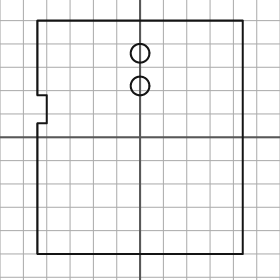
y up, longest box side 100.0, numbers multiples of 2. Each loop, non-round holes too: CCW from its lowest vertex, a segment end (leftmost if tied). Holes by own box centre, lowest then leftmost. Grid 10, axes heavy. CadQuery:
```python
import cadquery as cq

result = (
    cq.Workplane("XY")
    .moveTo(-44.0, -50.0)
    .lineTo(44.0, -50.0)
    .lineTo(44.0, 50.0)
    .lineTo(-44.0, 50.0)
    .lineTo(-44.0, 18.0)
    .lineTo(-40.0, 18.0)
    .lineTo(-40.0, 6.0)
    .lineTo(-44.0, 6.0)
    .close()
    .moveTo(0.0, 22.0)
    .circle(4.0)
    .moveTo(0.0, 36.0)
    .circle(4.0)
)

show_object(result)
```